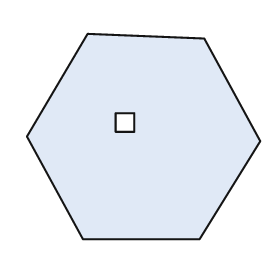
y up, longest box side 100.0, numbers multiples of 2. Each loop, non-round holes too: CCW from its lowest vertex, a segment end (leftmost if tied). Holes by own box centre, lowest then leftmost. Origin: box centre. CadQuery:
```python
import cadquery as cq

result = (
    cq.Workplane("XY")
    .moveTo(-26.0, -44.0)
    .lineTo(24.0, -44.0)
    .lineTo(50.0, -2.0)
    .lineTo(26.0, 42.0)
    .lineTo(-24.0, 44.0)
    .lineTo(-50.0, 0.0)
    .close()
    .moveTo(-12.0, 2.0)
    .lineTo(-4.0, 2.0)
    .lineTo(-4.0, 10.0)
    .lineTo(-12.0, 10.0)
    .close()
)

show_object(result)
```